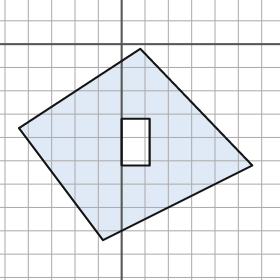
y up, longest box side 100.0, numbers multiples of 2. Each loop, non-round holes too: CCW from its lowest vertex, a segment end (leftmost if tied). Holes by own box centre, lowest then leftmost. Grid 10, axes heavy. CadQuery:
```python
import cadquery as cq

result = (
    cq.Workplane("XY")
    .moveTo(-8.0, -84.0)
    .lineTo(56.0, -52.0)
    .lineTo(8.0, -2.0)
    .lineTo(-44.0, -36.0)
    .close()
    .moveTo(0.0, -52.0)
    .lineTo(12.0, -52.0)
    .lineTo(12.0, -32.0)
    .lineTo(0.0, -32.0)
    .close()
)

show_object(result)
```